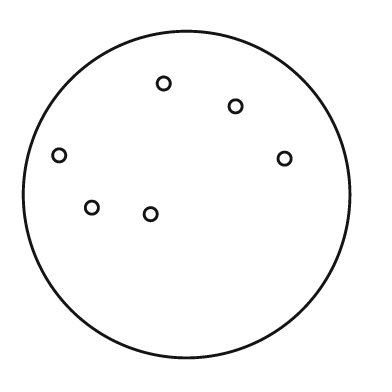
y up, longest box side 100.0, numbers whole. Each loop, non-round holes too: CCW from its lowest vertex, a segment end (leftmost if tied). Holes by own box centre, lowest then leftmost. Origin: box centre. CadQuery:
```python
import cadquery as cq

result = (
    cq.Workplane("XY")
    .moveTo(0.0, 0.0)
    .circle(50.0)
    .moveTo(-11.0, -6.0)
    .circle(2.0)
    .moveTo(-29.0, -4.0)
    .circle(2.0)
    .moveTo(30.0, 11.0)
    .circle(2.0)
    .moveTo(-39.0, 12.0)
    .circle(2.0)
    .moveTo(15.0, 27.0)
    .circle(2.0)
    .moveTo(-7.0, 34.0)
    .circle(2.0)
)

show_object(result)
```